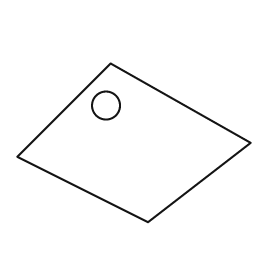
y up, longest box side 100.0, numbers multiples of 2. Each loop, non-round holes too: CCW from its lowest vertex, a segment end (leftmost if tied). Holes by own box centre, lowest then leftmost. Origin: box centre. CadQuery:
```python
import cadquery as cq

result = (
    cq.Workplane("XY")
    .moveTo(6.0, -34.0)
    .lineTo(50.0, 0.0)
    .lineTo(-10.0, 34.0)
    .lineTo(-50.0, -6.0)
    .close()
    .moveTo(-12.0, 16.0)
    .circle(6.0)
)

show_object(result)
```